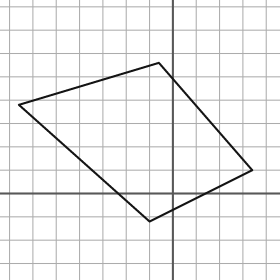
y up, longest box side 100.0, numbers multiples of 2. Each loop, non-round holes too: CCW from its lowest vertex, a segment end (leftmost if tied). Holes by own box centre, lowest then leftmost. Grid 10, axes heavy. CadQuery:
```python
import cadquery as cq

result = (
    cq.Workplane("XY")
    .moveTo(-10.0, -12.0)
    .lineTo(34.0, 10.0)
    .lineTo(-6.0, 56.0)
    .lineTo(-66.0, 38.0)
    .close()
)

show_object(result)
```